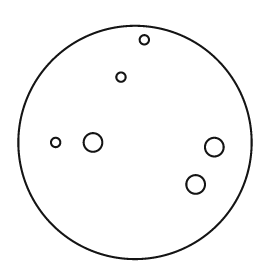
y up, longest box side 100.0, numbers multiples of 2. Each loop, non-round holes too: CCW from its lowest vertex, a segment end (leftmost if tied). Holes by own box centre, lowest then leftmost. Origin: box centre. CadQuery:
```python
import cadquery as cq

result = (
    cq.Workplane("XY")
    .moveTo(0.0, 0.0)
    .circle(50.0)
    .moveTo(26.0, -18.0)
    .circle(4.0)
    .moveTo(34.0, -2.0)
    .circle(4.0)
    .moveTo(-34.0, 0.0)
    .circle(2.0)
    .moveTo(-18.0, 0.0)
    .circle(4.0)
    .moveTo(-6.0, 28.0)
    .circle(2.0)
    .moveTo(4.0, 44.0)
    .circle(2.0)
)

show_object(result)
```